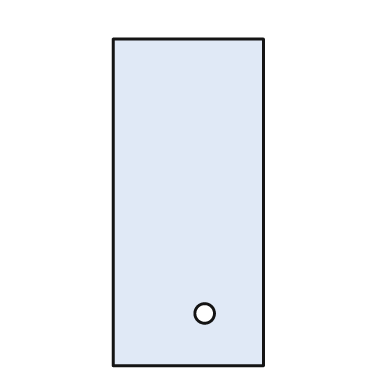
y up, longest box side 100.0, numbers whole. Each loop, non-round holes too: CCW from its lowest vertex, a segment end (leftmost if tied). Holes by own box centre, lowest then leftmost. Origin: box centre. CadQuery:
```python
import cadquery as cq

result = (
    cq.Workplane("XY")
    .moveTo(-23.0, -50.0)
    .lineTo(23.0, -50.0)
    .lineTo(23.0, 50.0)
    .lineTo(-23.0, 50.0)
    .close()
    .moveTo(5.0, -34.0)
    .circle(3.0)
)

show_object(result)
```